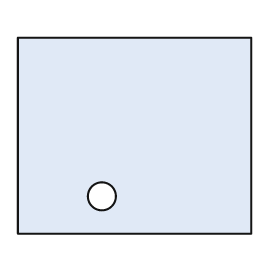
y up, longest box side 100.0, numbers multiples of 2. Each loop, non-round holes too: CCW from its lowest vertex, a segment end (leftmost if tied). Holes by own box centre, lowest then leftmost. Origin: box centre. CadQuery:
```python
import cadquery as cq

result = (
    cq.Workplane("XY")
    .moveTo(-50.0, -42.0)
    .lineTo(50.0, -42.0)
    .lineTo(50.0, 42.0)
    .lineTo(-50.0, 42.0)
    .close()
    .moveTo(-14.0, -26.0)
    .circle(6.0)
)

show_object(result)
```